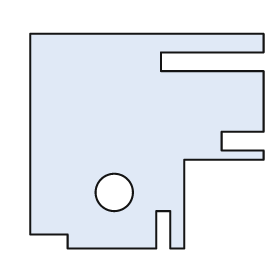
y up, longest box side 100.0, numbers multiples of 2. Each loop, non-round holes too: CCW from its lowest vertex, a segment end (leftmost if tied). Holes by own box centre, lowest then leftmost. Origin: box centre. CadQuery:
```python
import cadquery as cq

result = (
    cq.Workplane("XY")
    .moveTo(-34.0, -46.0)
    .lineTo(4.0, -46.0)
    .lineTo(4.0, -30.0)
    .lineTo(10.0, -30.0)
    .lineTo(10.0, -46.0)
    .lineTo(16.0, -46.0)
    .lineTo(16.0, -8.0)
    .lineTo(50.0, -8.0)
    .lineTo(50.0, -4.0)
    .lineTo(32.0, -4.0)
    .lineTo(32.0, 4.0)
    .lineTo(50.0, 4.0)
    .lineTo(50.0, 30.0)
    .lineTo(6.0, 30.0)
    .lineTo(6.0, 38.0)
    .lineTo(50.0, 38.0)
    .lineTo(50.0, 46.0)
    .lineTo(-50.0, 46.0)
    .lineTo(-50.0, -40.0)
    .lineTo(-34.0, -40.0)
    .close()
    .moveTo(-14.0, -22.0)
    .circle(8.0)
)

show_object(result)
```